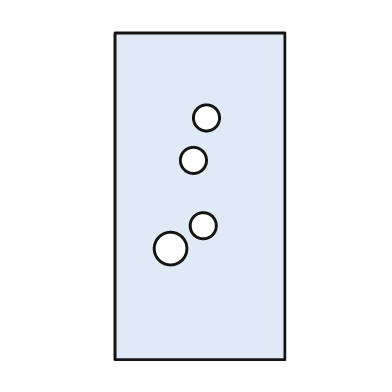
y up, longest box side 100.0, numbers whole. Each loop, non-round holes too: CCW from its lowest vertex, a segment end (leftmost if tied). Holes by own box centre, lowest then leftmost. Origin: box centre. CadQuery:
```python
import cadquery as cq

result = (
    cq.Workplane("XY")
    .moveTo(-26.0, -50.0)
    .lineTo(26.0, -50.0)
    .lineTo(26.0, 50.0)
    .lineTo(-26.0, 50.0)
    .close()
    .moveTo(-9.0, -16.0)
    .circle(5.0)
    .moveTo(1.0, -9.0)
    .circle(4.0)
    .moveTo(-2.0, 11.0)
    .circle(4.0)
    .moveTo(2.0, 24.0)
    .circle(4.0)
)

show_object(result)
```